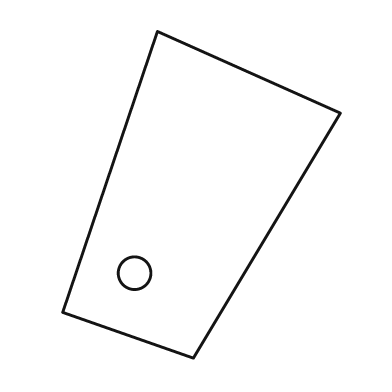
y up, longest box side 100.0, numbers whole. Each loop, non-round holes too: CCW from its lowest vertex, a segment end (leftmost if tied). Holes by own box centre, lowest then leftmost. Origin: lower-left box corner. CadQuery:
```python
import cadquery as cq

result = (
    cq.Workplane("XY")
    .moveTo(40.0, 0.0)
    .lineTo(85.0, 75.0)
    .lineTo(29.0, 100.0)
    .lineTo(0.0, 14.0)
    .close()
    .moveTo(22.0, 26.0)
    .circle(5.0)
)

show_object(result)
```